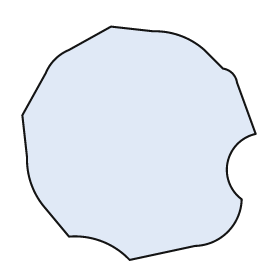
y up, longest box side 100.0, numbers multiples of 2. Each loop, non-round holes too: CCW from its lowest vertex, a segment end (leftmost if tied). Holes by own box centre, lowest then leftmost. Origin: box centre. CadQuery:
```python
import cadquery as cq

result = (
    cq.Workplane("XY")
    .moveTo(-4.0, -50.0)
    .lineTo(24.0, -44.0)
    .threePointArc((38.0, -38.0), (44.0, -24.0))
    .threePointArc((38.0, -8.0), (50.0, 4.0))
    .lineTo(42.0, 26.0)
    .threePointArc((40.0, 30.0), (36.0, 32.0))
    .lineTo(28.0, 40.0)
    .threePointArc((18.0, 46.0), (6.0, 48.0))
    .lineTo(-12.0, 50.0)
    .lineTo(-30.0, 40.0)
    .threePointArc((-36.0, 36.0), (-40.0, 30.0))
    .lineTo(-50.0, 12.0)
    .lineTo(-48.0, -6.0)
    .threePointArc((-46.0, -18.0), (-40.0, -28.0))
    .lineTo(-30.0, -40.0)
    .threePointArc((-16.0, -42.0), (-4.0, -50.0))
    .close()
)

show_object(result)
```